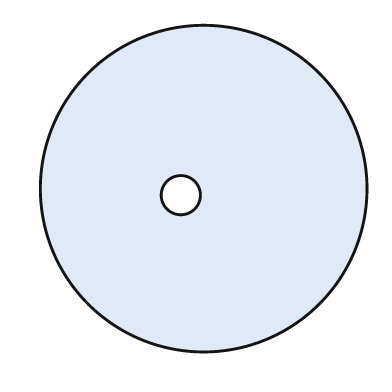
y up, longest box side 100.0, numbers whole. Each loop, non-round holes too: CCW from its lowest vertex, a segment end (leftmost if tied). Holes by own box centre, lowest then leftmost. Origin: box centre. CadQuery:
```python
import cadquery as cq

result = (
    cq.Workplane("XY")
    .moveTo(0.0, 0.0)
    .circle(50.0)
    .moveTo(-7.0, -2.0)
    .circle(6.0)
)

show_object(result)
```